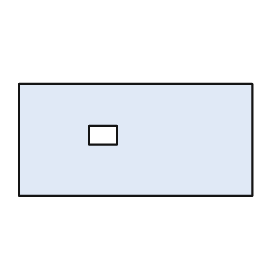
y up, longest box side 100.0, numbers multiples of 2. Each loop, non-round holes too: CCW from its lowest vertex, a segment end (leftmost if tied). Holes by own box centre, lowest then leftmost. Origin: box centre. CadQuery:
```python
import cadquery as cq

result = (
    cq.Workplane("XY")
    .moveTo(-50.0, -24.0)
    .lineTo(50.0, -24.0)
    .lineTo(50.0, 24.0)
    .lineTo(-50.0, 24.0)
    .close()
    .moveTo(-20.0, -2.0)
    .lineTo(-8.0, -2.0)
    .lineTo(-8.0, 6.0)
    .lineTo(-20.0, 6.0)
    .close()
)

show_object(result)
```